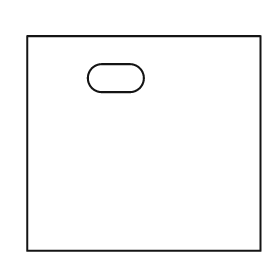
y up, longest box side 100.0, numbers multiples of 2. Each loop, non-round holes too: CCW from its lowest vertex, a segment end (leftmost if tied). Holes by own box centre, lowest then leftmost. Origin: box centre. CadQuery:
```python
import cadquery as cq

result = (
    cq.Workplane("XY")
    .moveTo(-50.0, -46.0)
    .lineTo(50.0, -46.0)
    .lineTo(50.0, 46.0)
    .lineTo(-50.0, 46.0)
    .close()
    .moveTo(-18.0, 22.0)
    .lineTo(-6.0, 22.0)
    .threePointArc((0.0, 28.0), (-6.0, 34.0))
    .lineTo(-18.0, 34.0)
    .threePointArc((-24.0, 28.0), (-18.0, 22.0))
    .close()
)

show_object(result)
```